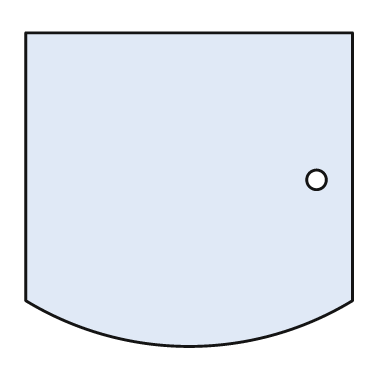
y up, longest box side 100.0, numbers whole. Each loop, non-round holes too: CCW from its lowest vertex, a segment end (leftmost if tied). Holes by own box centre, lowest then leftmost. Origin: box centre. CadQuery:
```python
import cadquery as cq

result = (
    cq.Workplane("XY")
    .moveTo(-50.0, -34.0)
    .threePointArc((0.0, -48.0), (50.0, -34.0))
    .lineTo(50.0, 48.0)
    .lineTo(-50.0, 48.0)
    .close()
    .moveTo(39.0, 3.0)
    .circle(3.0)
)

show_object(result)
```